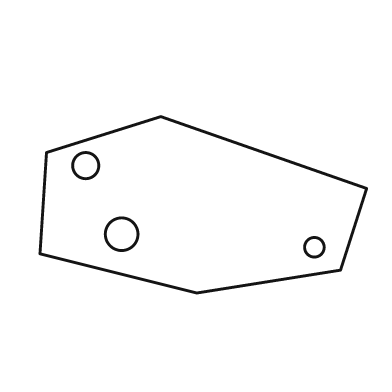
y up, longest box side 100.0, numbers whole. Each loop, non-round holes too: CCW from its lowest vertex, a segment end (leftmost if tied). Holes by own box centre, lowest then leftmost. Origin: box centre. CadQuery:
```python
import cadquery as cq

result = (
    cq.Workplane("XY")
    .moveTo(-2.0, -27.0)
    .lineTo(42.0, -20.0)
    .lineTo(50.0, 5.0)
    .lineTo(-13.0, 27.0)
    .lineTo(-48.0, 16.0)
    .lineTo(-50.0, -15.0)
    .close()
    .moveTo(34.0, -13.0)
    .circle(3.0)
    .moveTo(-25.0, -9.0)
    .circle(5.0)
    .moveTo(-36.0, 12.0)
    .circle(4.0)
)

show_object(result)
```